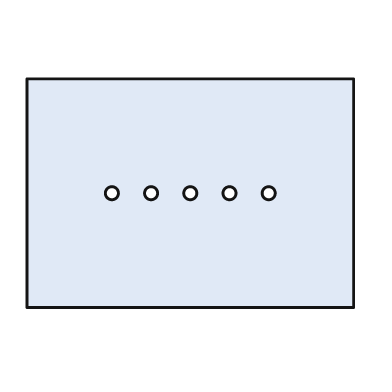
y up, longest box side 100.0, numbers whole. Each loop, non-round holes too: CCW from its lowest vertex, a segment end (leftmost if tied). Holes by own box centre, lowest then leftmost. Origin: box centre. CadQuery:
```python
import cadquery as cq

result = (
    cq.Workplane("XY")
    .moveTo(-50.0, -35.0)
    .lineTo(50.0, -35.0)
    .lineTo(50.0, 35.0)
    .lineTo(-50.0, 35.0)
    .close()
    .moveTo(-24.0, 0.0)
    .circle(2.0)
    .moveTo(-12.0, 0.0)
    .circle(2.0)
    .moveTo(0.0, 0.0)
    .circle(2.0)
    .moveTo(12.0, 0.0)
    .circle(2.0)
    .moveTo(24.0, 0.0)
    .circle(2.0)
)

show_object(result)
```